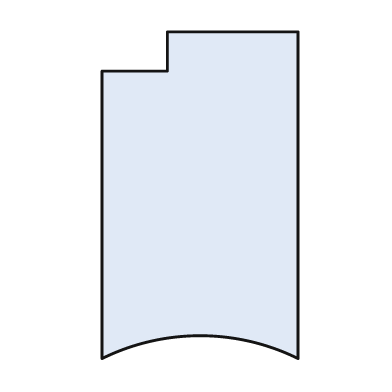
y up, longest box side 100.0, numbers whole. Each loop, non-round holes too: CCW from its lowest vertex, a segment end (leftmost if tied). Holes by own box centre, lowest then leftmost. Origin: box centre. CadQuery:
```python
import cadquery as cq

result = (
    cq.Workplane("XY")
    .moveTo(-30.0, -50.0)
    .threePointArc((0.0, -43.0), (30.0, -50.0))
    .lineTo(30.0, 50.0)
    .lineTo(-10.0, 50.0)
    .lineTo(-10.0, 38.0)
    .lineTo(-30.0, 38.0)
    .close()
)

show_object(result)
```